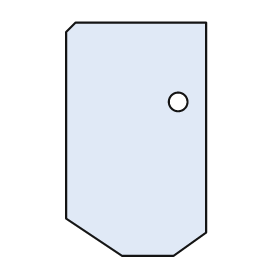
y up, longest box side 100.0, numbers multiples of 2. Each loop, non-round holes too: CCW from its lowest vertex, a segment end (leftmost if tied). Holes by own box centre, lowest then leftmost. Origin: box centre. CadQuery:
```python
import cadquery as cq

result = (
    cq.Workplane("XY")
    .moveTo(-6.0, -50.0)
    .lineTo(16.0, -50.0)
    .lineTo(30.0, -40.0)
    .lineTo(30.0, 50.0)
    .lineTo(-26.0, 50.0)
    .lineTo(-30.0, 46.0)
    .lineTo(-30.0, -34.0)
    .close()
    .moveTo(18.0, 16.0)
    .circle(4.0)
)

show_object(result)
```